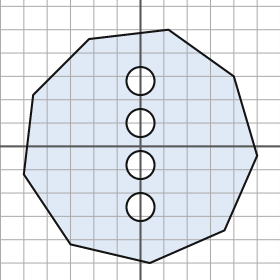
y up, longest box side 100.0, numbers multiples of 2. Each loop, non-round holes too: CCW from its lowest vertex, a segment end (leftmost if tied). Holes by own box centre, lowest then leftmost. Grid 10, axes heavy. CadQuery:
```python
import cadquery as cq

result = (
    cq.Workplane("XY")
    .moveTo(4.0, -50.0)
    .lineTo(36.0, -36.0)
    .lineTo(50.0, -4.0)
    .lineTo(40.0, 30.0)
    .lineTo(12.0, 50.0)
    .lineTo(-22.0, 46.0)
    .lineTo(-46.0, 22.0)
    .lineTo(-50.0, -12.0)
    .lineTo(-30.0, -42.0)
    .close()
    .moveTo(0.0, -26.0)
    .circle(6.0)
    .moveTo(0.0, -8.0)
    .circle(6.0)
    .moveTo(0.0, 10.0)
    .circle(6.0)
    .moveTo(0.0, 28.0)
    .circle(6.0)
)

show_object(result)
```